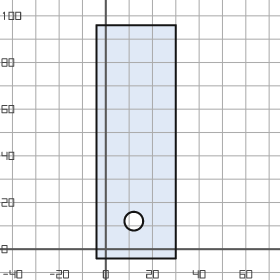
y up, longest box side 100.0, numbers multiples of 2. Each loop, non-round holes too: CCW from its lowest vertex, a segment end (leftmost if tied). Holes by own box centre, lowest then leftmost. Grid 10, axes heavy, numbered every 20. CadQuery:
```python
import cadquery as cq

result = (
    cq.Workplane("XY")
    .moveTo(-4.0, -4.0)
    .lineTo(30.0, -4.0)
    .lineTo(30.0, 96.0)
    .lineTo(-4.0, 96.0)
    .close()
    .moveTo(12.0, 12.0)
    .circle(4.0)
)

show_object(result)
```